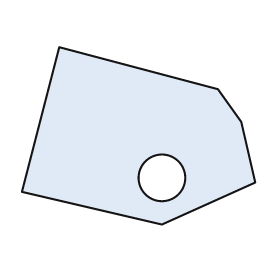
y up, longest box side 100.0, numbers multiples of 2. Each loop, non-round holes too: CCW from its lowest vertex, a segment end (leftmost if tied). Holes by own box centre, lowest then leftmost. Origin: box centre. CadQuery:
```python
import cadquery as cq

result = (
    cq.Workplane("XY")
    .moveTo(10.0, -38.0)
    .lineTo(50.0, -20.0)
    .lineTo(44.0, 6.0)
    .lineTo(34.0, 20.0)
    .lineTo(-34.0, 38.0)
    .lineTo(-50.0, -24.0)
    .close()
    .moveTo(10.0, -18.0)
    .circle(10.0)
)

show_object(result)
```